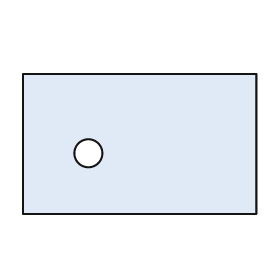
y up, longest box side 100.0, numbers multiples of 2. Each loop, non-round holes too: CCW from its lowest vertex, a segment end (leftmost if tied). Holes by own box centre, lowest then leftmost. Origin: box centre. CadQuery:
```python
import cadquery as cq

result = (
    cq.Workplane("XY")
    .moveTo(-50.0, -30.0)
    .lineTo(50.0, -30.0)
    .lineTo(50.0, 30.0)
    .lineTo(-50.0, 30.0)
    .close()
    .moveTo(-22.0, -4.0)
    .circle(6.0)
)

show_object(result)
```